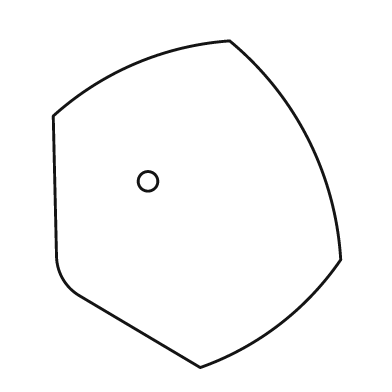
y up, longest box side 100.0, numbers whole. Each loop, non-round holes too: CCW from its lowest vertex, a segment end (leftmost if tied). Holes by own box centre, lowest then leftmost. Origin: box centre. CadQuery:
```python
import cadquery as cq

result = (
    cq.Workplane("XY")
    .moveTo(1.0, -50.0)
    .threePointArc((25.0, -37.0), (44.0, -17.0))
    .threePointArc((34.0, 20.0), (10.0, 50.0))
    .threePointArc((-19.0, 43.0), (-44.0, 27.0))
    .lineTo(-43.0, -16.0)
    .threePointArc((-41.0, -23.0), (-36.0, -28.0))
    .close()
    .moveTo(-15.0, 7.0)
    .circle(3.0)
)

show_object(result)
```